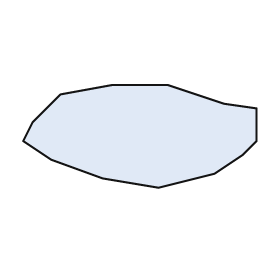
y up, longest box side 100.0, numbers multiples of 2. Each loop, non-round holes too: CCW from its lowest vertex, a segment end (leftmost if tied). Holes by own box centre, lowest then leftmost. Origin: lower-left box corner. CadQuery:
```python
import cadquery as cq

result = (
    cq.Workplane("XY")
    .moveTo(58.0, 0.0)
    .lineTo(82.0, 6.0)
    .lineTo(94.0, 14.0)
    .lineTo(100.0, 20.0)
    .lineTo(100.0, 34.0)
    .lineTo(86.0, 36.0)
    .lineTo(62.0, 44.0)
    .lineTo(38.0, 44.0)
    .lineTo(16.0, 40.0)
    .lineTo(4.0, 28.0)
    .lineTo(0.0, 20.0)
    .lineTo(12.0, 12.0)
    .lineTo(34.0, 4.0)
    .close()
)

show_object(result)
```